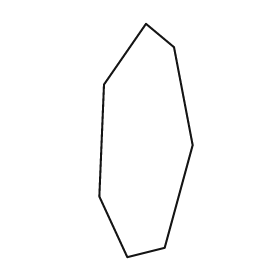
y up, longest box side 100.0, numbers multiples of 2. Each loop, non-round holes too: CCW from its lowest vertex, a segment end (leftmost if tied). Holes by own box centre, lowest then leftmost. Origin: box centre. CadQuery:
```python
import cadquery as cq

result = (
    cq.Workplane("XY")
    .moveTo(-8.0, -50.0)
    .lineTo(8.0, -46.0)
    .lineTo(20.0, -2.0)
    .lineTo(12.0, 40.0)
    .lineTo(0.0, 50.0)
    .lineTo(-18.0, 24.0)
    .lineTo(-20.0, -24.0)
    .close()
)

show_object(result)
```